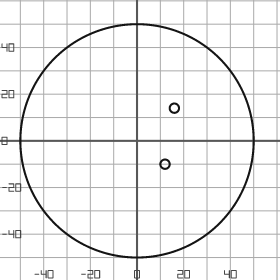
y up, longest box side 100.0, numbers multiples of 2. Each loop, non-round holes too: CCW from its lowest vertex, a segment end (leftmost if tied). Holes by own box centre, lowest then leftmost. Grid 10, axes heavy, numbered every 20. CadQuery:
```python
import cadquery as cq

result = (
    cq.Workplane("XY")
    .moveTo(0.0, 0.0)
    .circle(50.0)
    .moveTo(12.0, -10.0)
    .circle(2.0)
    .moveTo(16.0, 14.0)
    .circle(2.0)
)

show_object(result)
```